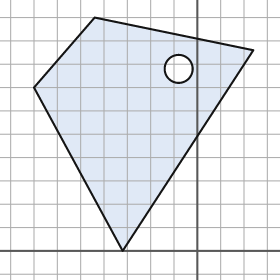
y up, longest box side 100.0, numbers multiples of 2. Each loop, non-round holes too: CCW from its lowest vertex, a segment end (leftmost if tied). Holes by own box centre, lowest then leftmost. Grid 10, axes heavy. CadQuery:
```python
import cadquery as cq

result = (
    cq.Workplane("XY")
    .moveTo(-32.0, 0.0)
    .lineTo(24.0, 86.0)
    .lineTo(-44.0, 100.0)
    .lineTo(-70.0, 70.0)
    .close()
    .moveTo(-8.0, 78.0)
    .circle(6.0)
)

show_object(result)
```